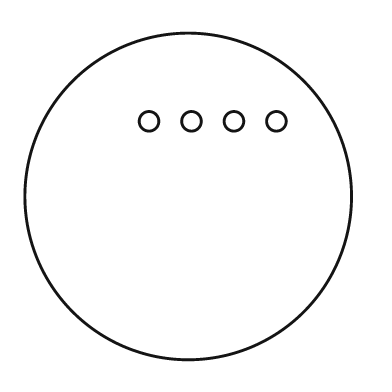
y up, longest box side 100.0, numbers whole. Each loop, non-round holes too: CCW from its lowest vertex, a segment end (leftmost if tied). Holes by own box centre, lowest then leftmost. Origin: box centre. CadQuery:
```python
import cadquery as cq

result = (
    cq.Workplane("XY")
    .moveTo(0.0, 0.0)
    .circle(50.0)
    .moveTo(-12.0, 23.0)
    .circle(3.0)
    .moveTo(1.0, 23.0)
    .circle(3.0)
    .moveTo(14.0, 23.0)
    .circle(3.0)
    .moveTo(27.0, 23.0)
    .circle(3.0)
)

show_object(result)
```